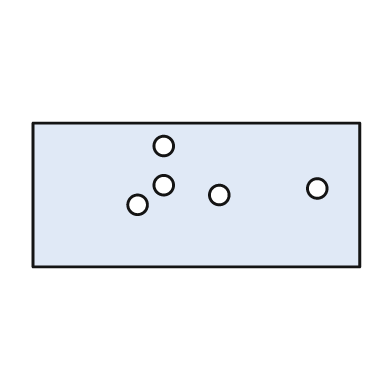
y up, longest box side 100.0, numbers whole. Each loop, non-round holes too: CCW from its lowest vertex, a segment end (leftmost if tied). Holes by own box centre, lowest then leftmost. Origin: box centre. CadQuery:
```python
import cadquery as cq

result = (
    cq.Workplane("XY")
    .moveTo(-50.0, -22.0)
    .lineTo(50.0, -22.0)
    .lineTo(50.0, 22.0)
    .lineTo(-50.0, 22.0)
    .close()
    .moveTo(-18.0, -3.0)
    .circle(3.0)
    .moveTo(7.0, 0.0)
    .circle(3.0)
    .moveTo(37.0, 2.0)
    .circle(3.0)
    .moveTo(-10.0, 3.0)
    .circle(3.0)
    .moveTo(-10.0, 15.0)
    .circle(3.0)
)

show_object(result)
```